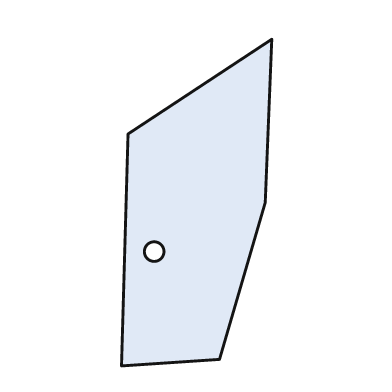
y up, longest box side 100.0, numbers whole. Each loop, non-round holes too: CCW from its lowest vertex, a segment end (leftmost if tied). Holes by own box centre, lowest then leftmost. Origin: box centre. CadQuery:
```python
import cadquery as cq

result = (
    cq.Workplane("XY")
    .moveTo(-23.0, -50.0)
    .lineTo(7.0, -48.0)
    .lineTo(21.0, 0.0)
    .lineTo(23.0, 50.0)
    .lineTo(-21.0, 21.0)
    .close()
    .moveTo(-13.0, -15.0)
    .circle(3.0)
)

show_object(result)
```